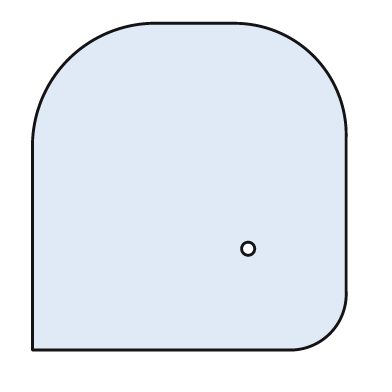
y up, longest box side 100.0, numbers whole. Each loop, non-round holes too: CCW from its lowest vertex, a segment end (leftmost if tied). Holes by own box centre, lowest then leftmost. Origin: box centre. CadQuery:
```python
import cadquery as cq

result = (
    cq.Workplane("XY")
    .moveTo(-48.0, -50.0)
    .lineTo(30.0, -50.0)
    .threePointArc((43.0, -45.0), (48.0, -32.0))
    .lineTo(48.0, 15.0)
    .threePointArc((38.0, 40.0), (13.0, 50.0))
    .lineTo(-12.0, 50.0)
    .threePointArc((-37.0, 39.0), (-48.0, 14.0))
    .close()
    .moveTo(18.0, -19.0)
    .circle(2.0)
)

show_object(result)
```